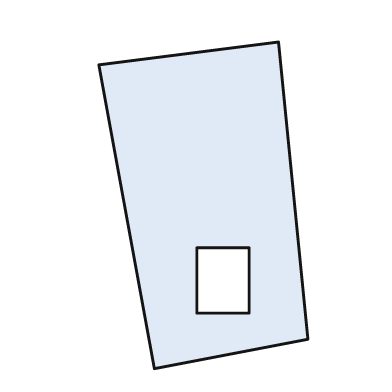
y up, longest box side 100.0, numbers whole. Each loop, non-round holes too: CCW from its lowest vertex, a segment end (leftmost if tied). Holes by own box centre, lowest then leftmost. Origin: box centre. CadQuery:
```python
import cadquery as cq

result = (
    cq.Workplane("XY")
    .moveTo(-15.0, -50.0)
    .lineTo(32.0, -41.0)
    .lineTo(23.0, 50.0)
    .lineTo(-32.0, 43.0)
    .close()
    .moveTo(-2.0, -33.0)
    .lineTo(14.0, -33.0)
    .lineTo(14.0, -13.0)
    .lineTo(-2.0, -13.0)
    .close()
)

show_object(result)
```